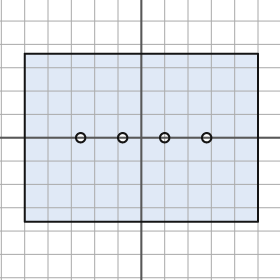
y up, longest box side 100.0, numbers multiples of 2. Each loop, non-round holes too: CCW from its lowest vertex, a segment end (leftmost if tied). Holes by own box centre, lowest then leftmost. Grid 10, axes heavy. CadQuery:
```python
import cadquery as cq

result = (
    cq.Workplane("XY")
    .moveTo(-50.0, -36.0)
    .lineTo(50.0, -36.0)
    .lineTo(50.0, 36.0)
    .lineTo(-50.0, 36.0)
    .close()
    .moveTo(-26.0, 0.0)
    .circle(2.0)
    .moveTo(-8.0, 0.0)
    .circle(2.0)
    .moveTo(10.0, 0.0)
    .circle(2.0)
    .moveTo(28.0, 0.0)
    .circle(2.0)
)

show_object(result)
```